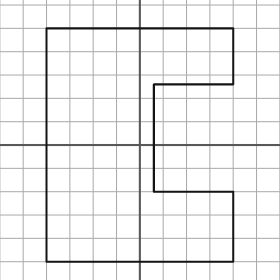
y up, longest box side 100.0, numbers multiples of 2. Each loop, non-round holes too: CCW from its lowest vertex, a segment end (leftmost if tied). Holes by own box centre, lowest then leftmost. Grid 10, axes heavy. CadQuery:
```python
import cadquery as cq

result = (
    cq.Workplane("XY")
    .moveTo(-40.0, -50.0)
    .lineTo(40.0, -50.0)
    .lineTo(40.0, -20.0)
    .lineTo(6.0, -20.0)
    .lineTo(6.0, 26.0)
    .lineTo(40.0, 26.0)
    .lineTo(40.0, 50.0)
    .lineTo(-40.0, 50.0)
    .close()
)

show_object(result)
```